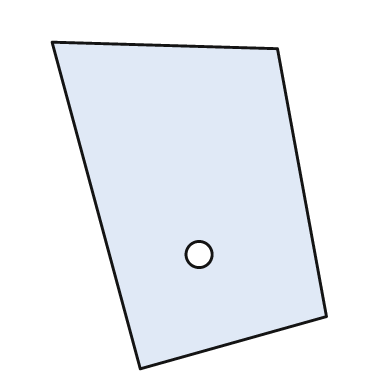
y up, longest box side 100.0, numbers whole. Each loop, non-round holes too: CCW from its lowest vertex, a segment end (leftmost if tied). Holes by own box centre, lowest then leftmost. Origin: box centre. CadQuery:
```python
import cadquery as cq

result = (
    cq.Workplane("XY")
    .moveTo(-15.0, -50.0)
    .lineTo(42.0, -34.0)
    .lineTo(27.0, 48.0)
    .lineTo(-42.0, 50.0)
    .close()
    .moveTo(3.0, -15.0)
    .circle(4.0)
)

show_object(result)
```